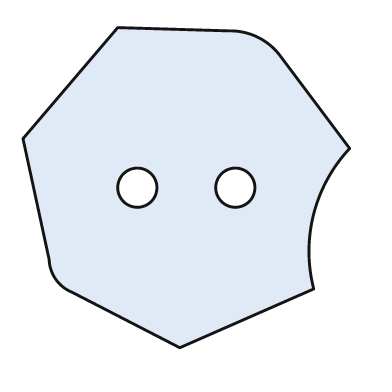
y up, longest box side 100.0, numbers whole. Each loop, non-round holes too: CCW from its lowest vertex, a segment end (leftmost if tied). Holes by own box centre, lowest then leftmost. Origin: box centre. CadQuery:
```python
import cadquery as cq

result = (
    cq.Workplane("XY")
    .moveTo(-2.0, -49.0)
    .lineTo(39.0, -31.0)
    .threePointArc((39.0, -8.0), (50.0, 12.0))
    .lineTo(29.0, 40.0)
    .threePointArc((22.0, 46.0), (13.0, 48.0))
    .lineTo(-21.0, 49.0)
    .lineTo(-50.0, 15.0)
    .lineTo(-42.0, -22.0)
    .threePointArc((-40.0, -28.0), (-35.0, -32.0))
    .close()
    .moveTo(-15.0, 0.0)
    .circle(6.0)
    .moveTo(15.0, 0.0)
    .circle(6.0)
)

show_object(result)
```